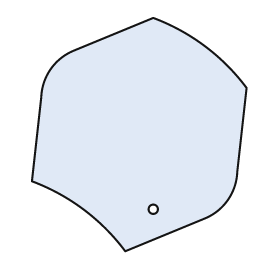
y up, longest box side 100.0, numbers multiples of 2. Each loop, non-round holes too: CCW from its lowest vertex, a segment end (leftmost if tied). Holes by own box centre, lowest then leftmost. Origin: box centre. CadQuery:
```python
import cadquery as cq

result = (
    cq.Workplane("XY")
    .moveTo(-6.0, -50.0)
    .lineTo(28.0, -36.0)
    .threePointArc((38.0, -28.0), (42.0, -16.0))
    .lineTo(46.0, 20.0)
    .threePointArc((28.0, 38.0), (6.0, 50.0))
    .lineTo(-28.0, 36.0)
    .threePointArc((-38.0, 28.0), (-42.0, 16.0))
    .lineTo(-46.0, -20.0)
    .threePointArc((-24.0, -32.0), (-6.0, -50.0))
    .close()
    .moveTo(6.0, -32.0)
    .circle(2.0)
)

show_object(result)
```